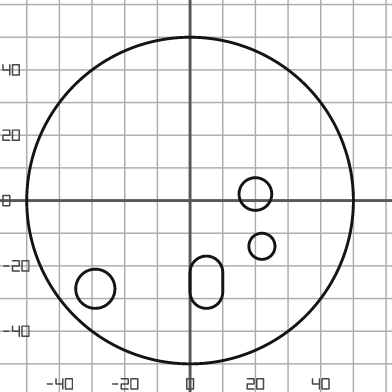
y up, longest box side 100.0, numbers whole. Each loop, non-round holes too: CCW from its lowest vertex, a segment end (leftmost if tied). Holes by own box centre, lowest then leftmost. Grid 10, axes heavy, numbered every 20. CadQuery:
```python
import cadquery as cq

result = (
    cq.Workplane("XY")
    .moveTo(0.0, 0.0)
    .circle(50.0)
    .moveTo(-29.0, -27.0)
    .circle(6.0)
    .moveTo(0.0, -28.0)
    .threePointArc((5.0, -33.0), (10.0, -28.0))
    .lineTo(10.0, -22.0)
    .threePointArc((5.0, -17.0), (0.0, -22.0))
    .close()
    .moveTo(22.0, -14.0)
    .circle(4.0)
    .moveTo(20.0, 2.0)
    .circle(5.0)
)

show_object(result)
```